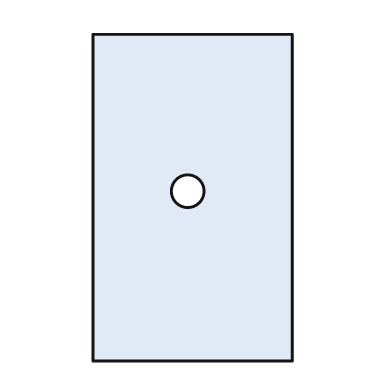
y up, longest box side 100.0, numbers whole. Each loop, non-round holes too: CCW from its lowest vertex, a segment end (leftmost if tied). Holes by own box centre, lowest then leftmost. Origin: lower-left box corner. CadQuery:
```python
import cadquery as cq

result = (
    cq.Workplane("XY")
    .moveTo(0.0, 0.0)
    .lineTo(61.0, 0.0)
    .lineTo(61.0, 100.0)
    .lineTo(0.0, 100.0)
    .close()
    .moveTo(29.0, 52.0)
    .circle(5.0)
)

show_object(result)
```